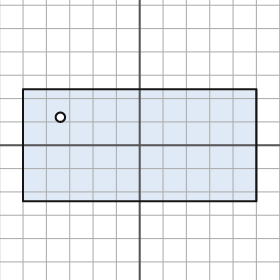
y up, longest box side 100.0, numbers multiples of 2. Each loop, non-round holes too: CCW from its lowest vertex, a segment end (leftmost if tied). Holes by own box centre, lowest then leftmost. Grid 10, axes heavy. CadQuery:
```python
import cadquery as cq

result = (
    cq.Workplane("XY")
    .moveTo(-50.0, -24.0)
    .lineTo(50.0, -24.0)
    .lineTo(50.0, 24.0)
    .lineTo(-50.0, 24.0)
    .close()
    .moveTo(-34.0, 12.0)
    .circle(2.0)
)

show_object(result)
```